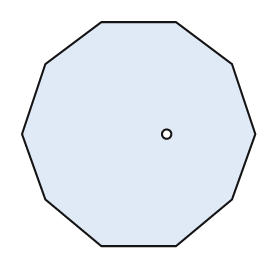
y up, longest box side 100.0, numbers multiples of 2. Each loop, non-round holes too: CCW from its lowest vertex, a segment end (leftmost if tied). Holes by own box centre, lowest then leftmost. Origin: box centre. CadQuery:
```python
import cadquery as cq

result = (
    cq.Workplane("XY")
    .moveTo(-16.0, -48.0)
    .lineTo(16.0, -48.0)
    .lineTo(40.0, -28.0)
    .lineTo(50.0, 0.0)
    .lineTo(40.0, 30.0)
    .lineTo(16.0, 48.0)
    .lineTo(-16.0, 48.0)
    .lineTo(-40.0, 30.0)
    .lineTo(-50.0, 0.0)
    .lineTo(-40.0, -28.0)
    .close()
    .moveTo(12.0, 0.0)
    .circle(2.0)
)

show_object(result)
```